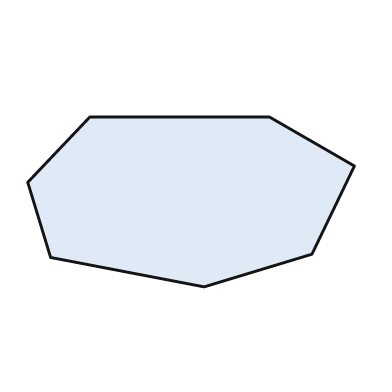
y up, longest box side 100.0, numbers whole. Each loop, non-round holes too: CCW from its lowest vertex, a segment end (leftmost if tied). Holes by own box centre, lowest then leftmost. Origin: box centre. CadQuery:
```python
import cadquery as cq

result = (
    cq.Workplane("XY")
    .moveTo(4.0, -26.0)
    .lineTo(37.0, -16.0)
    .lineTo(50.0, 11.0)
    .lineTo(24.0, 26.0)
    .lineTo(-31.0, 26.0)
    .lineTo(-50.0, 6.0)
    .lineTo(-43.0, -17.0)
    .close()
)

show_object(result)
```